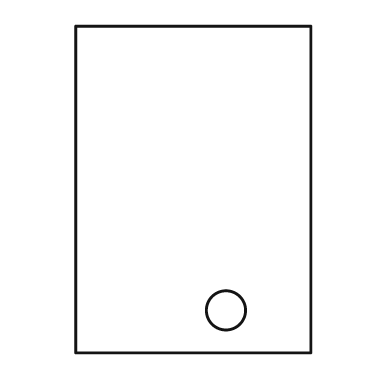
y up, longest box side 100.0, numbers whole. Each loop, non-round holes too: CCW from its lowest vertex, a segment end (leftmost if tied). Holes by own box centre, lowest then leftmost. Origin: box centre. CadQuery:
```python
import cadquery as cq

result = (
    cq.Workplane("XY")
    .moveTo(-36.0, -50.0)
    .lineTo(36.0, -50.0)
    .lineTo(36.0, 50.0)
    .lineTo(-36.0, 50.0)
    .close()
    .moveTo(10.0, -37.0)
    .circle(6.0)
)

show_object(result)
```